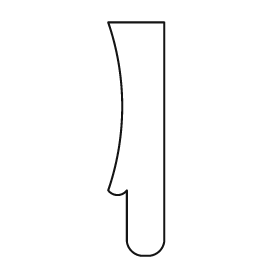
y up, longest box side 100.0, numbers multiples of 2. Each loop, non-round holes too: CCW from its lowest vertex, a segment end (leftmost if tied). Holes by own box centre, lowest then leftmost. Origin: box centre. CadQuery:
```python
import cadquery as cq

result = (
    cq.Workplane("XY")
    .moveTo(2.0, -50.0)
    .lineTo(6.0, -50.0)
    .threePointArc((10.0, -48.0), (12.0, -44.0))
    .lineTo(12.0, 50.0)
    .lineTo(-12.0, 50.0)
    .threePointArc((-6.0, 14.0), (-12.0, -22.0))
    .threePointArc((-8.0, -24.0), (-4.0, -22.0))
    .lineTo(-4.0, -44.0)
    .threePointArc((-2.0, -48.0), (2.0, -50.0))
    .close()
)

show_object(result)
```